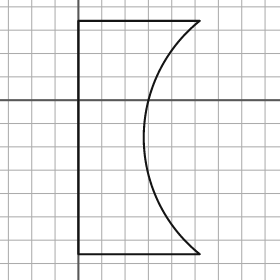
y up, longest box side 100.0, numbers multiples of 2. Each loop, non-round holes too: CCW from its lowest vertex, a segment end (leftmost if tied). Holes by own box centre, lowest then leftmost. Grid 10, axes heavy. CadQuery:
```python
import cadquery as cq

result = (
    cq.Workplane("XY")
    .moveTo(0.0, -66.0)
    .lineTo(52.0, -66.0)
    .threePointArc((28.0, -16.0), (52.0, 34.0))
    .lineTo(0.0, 34.0)
    .close()
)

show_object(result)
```